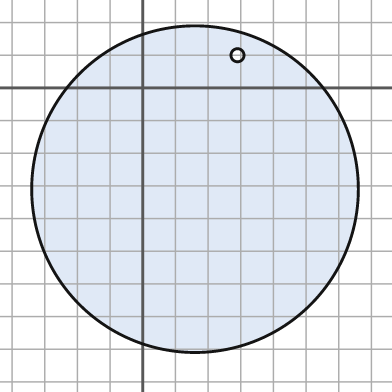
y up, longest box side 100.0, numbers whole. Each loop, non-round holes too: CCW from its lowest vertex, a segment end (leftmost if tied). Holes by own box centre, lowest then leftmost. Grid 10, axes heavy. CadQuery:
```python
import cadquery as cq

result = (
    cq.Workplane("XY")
    .moveTo(16.0, -31.0)
    .circle(50.0)
    .moveTo(29.0, 10.0)
    .circle(2.0)
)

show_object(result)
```